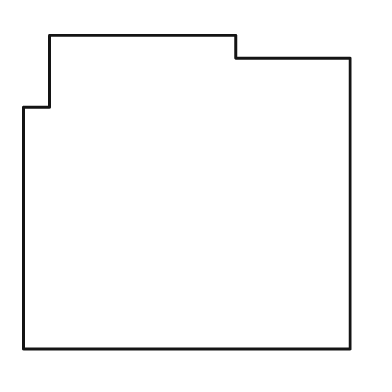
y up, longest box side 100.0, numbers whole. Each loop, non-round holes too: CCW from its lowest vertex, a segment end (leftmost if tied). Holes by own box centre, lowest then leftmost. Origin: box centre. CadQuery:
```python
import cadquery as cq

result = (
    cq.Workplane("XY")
    .moveTo(-50.0, -48.0)
    .lineTo(50.0, -48.0)
    .lineTo(50.0, 41.0)
    .lineTo(15.0, 41.0)
    .lineTo(15.0, 48.0)
    .lineTo(-42.0, 48.0)
    .lineTo(-42.0, 26.0)
    .lineTo(-50.0, 26.0)
    .close()
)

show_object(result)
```